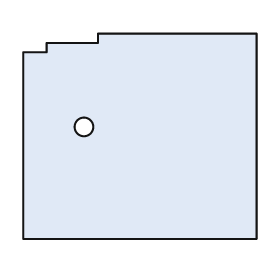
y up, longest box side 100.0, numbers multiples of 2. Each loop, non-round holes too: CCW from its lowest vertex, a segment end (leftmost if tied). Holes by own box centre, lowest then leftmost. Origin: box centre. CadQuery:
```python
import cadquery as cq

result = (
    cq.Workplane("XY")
    .moveTo(-50.0, -44.0)
    .lineTo(50.0, -44.0)
    .lineTo(50.0, 44.0)
    .lineTo(-18.0, 44.0)
    .lineTo(-18.0, 40.0)
    .lineTo(-40.0, 40.0)
    .lineTo(-40.0, 36.0)
    .lineTo(-50.0, 36.0)
    .close()
    .moveTo(-24.0, 4.0)
    .circle(4.0)
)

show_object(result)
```